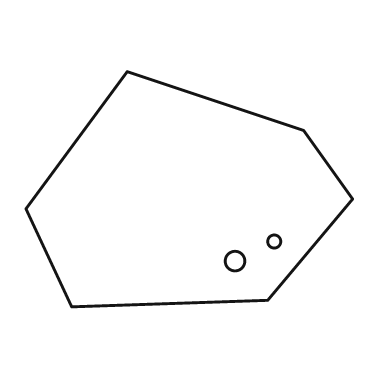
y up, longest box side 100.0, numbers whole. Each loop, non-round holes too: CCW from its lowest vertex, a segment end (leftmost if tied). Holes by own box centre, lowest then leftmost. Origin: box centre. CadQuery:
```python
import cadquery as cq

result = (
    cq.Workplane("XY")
    .moveTo(-36.0, -36.0)
    .lineTo(24.0, -34.0)
    .lineTo(50.0, -3.0)
    .lineTo(35.0, 18.0)
    .lineTo(-19.0, 36.0)
    .lineTo(-50.0, -6.0)
    .close()
    .moveTo(14.0, -22.0)
    .circle(3.0)
    .moveTo(26.0, -16.0)
    .circle(2.0)
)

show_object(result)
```